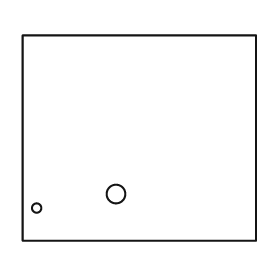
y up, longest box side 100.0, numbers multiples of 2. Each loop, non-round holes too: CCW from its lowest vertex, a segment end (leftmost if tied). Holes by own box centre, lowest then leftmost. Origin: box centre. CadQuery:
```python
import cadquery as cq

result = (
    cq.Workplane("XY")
    .moveTo(-50.0, -44.0)
    .lineTo(50.0, -44.0)
    .lineTo(50.0, 44.0)
    .lineTo(-50.0, 44.0)
    .close()
    .moveTo(-44.0, -30.0)
    .circle(2.0)
    .moveTo(-10.0, -24.0)
    .circle(4.0)
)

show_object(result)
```